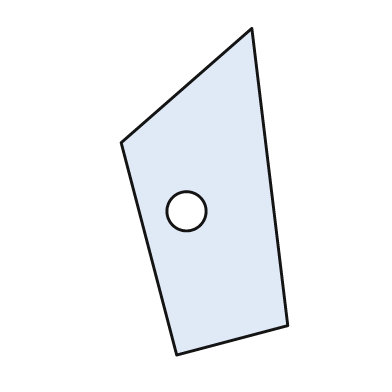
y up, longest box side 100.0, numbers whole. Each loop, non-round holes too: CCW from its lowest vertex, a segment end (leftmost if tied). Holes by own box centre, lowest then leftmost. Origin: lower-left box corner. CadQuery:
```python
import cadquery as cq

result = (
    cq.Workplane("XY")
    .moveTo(17.0, 0.0)
    .lineTo(51.0, 9.0)
    .lineTo(40.0, 100.0)
    .lineTo(0.0, 65.0)
    .close()
    .moveTo(20.0, 44.0)
    .circle(6.0)
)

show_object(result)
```